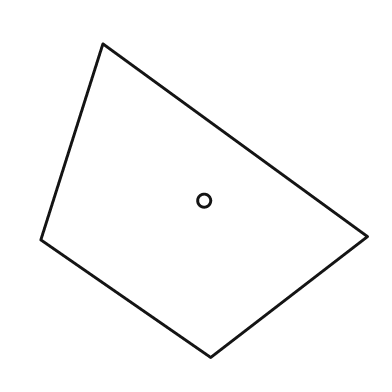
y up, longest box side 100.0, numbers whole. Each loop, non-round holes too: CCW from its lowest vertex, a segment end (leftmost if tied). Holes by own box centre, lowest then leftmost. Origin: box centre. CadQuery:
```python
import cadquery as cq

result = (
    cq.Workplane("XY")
    .moveTo(2.0, -48.0)
    .lineTo(50.0, -11.0)
    .lineTo(-31.0, 48.0)
    .lineTo(-50.0, -12.0)
    .close()
    .moveTo(0.0, 0.0)
    .circle(2.0)
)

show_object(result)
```